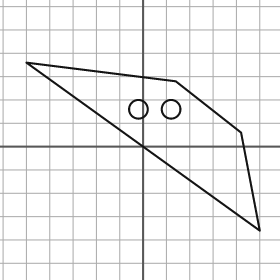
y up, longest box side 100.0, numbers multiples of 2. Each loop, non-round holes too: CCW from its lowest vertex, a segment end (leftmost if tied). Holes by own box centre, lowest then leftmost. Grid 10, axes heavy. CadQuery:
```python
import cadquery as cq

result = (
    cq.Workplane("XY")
    .moveTo(50.0, -36.0)
    .lineTo(42.0, 6.0)
    .lineTo(14.0, 28.0)
    .lineTo(-50.0, 36.0)
    .close()
    .moveTo(-2.0, 16.0)
    .circle(4.0)
    .moveTo(12.0, 16.0)
    .circle(4.0)
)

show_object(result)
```